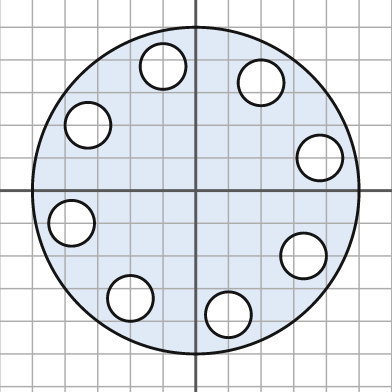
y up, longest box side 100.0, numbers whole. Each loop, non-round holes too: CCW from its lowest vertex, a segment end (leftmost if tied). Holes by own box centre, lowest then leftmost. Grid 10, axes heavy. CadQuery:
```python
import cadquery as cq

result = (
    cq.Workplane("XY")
    .moveTo(0.0, 0.0)
    .circle(50.0)
    .moveTo(10.0, -38.0)
    .circle(7.0)
    .moveTo(-20.0, -33.0)
    .circle(7.0)
    .moveTo(33.0, -20.0)
    .circle(7.0)
    .moveTo(-38.0, -10.0)
    .circle(7.0)
    .moveTo(38.0, 10.0)
    .circle(7.0)
    .moveTo(-33.0, 20.0)
    .circle(7.0)
    .moveTo(20.0, 33.0)
    .circle(7.0)
    .moveTo(-10.0, 38.0)
    .circle(7.0)
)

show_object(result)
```